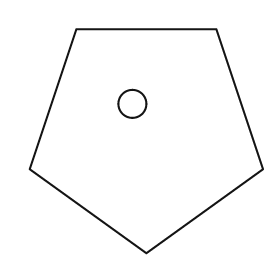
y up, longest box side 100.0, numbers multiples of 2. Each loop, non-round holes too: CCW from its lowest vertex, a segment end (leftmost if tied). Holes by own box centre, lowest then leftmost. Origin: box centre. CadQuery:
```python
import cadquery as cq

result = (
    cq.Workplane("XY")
    .moveTo(0.0, -48.0)
    .lineTo(50.0, -12.0)
    .lineTo(30.0, 48.0)
    .lineTo(-30.0, 48.0)
    .lineTo(-50.0, -12.0)
    .close()
    .moveTo(-6.0, 16.0)
    .circle(6.0)
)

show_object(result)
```